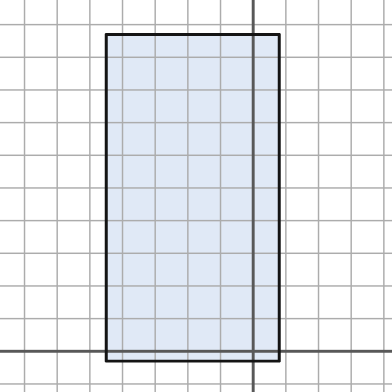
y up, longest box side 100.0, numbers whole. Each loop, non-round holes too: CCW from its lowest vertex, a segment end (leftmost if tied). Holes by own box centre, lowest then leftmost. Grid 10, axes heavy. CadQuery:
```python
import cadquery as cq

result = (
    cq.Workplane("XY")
    .moveTo(-45.0, -3.0)
    .lineTo(8.0, -3.0)
    .lineTo(8.0, 97.0)
    .lineTo(-45.0, 97.0)
    .close()
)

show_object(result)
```